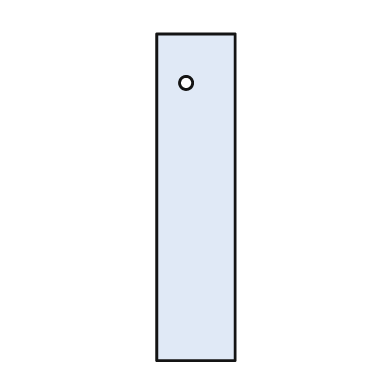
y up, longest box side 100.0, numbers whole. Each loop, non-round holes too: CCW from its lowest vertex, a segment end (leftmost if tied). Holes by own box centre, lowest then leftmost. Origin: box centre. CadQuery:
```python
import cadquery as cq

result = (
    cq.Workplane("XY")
    .moveTo(-12.0, -50.0)
    .lineTo(12.0, -50.0)
    .lineTo(12.0, 50.0)
    .lineTo(-12.0, 50.0)
    .close()
    .moveTo(-3.0, 35.0)
    .circle(2.0)
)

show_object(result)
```